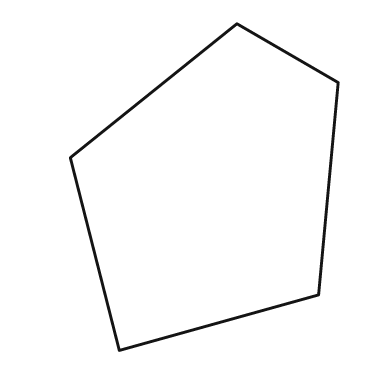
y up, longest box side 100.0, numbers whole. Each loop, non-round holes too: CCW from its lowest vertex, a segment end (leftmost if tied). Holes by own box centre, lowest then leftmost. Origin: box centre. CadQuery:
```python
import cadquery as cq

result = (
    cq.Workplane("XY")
    .moveTo(-26.0, -50.0)
    .lineTo(35.0, -33.0)
    .lineTo(41.0, 32.0)
    .lineTo(10.0, 50.0)
    .lineTo(-41.0, 9.0)
    .close()
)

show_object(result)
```